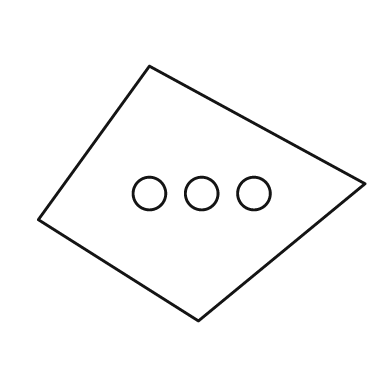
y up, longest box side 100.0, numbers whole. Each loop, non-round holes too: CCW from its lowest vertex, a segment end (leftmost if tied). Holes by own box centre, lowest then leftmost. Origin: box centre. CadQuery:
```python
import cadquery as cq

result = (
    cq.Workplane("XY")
    .moveTo(-1.0, -39.0)
    .lineTo(50.0, 3.0)
    .lineTo(-16.0, 39.0)
    .lineTo(-50.0, -8.0)
    .close()
    .moveTo(-16.0, 0.0)
    .circle(5.0)
    .moveTo(0.0, 0.0)
    .circle(5.0)
    .moveTo(16.0, 0.0)
    .circle(5.0)
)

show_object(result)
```